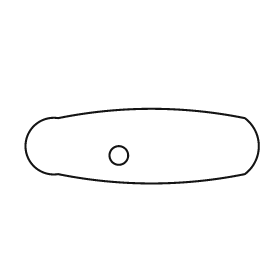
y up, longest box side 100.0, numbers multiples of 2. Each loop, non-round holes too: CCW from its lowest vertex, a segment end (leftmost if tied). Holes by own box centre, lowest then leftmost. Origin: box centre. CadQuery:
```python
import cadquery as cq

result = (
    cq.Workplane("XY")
    .moveTo(-36.0, -12.0)
    .threePointArc((4.0, -16.0), (44.0, -12.0))
    .threePointArc((50.0, 0.0), (44.0, 12.0))
    .threePointArc((4.0, 16.0), (-36.0, 12.0))
    .threePointArc((-50.0, 0.0), (-36.0, -12.0))
    .close()
    .moveTo(-10.0, -4.0)
    .circle(4.0)
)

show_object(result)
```